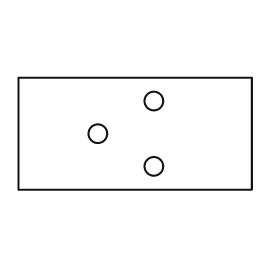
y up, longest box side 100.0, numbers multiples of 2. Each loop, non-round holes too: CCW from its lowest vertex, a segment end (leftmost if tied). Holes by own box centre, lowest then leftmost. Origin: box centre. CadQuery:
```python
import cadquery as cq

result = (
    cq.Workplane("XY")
    .moveTo(-50.0, -24.0)
    .lineTo(50.0, -24.0)
    .lineTo(50.0, 24.0)
    .lineTo(-50.0, 24.0)
    .close()
    .moveTo(8.0, -14.0)
    .circle(4.0)
    .moveTo(-16.0, 0.0)
    .circle(4.0)
    .moveTo(8.0, 14.0)
    .circle(4.0)
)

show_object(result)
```